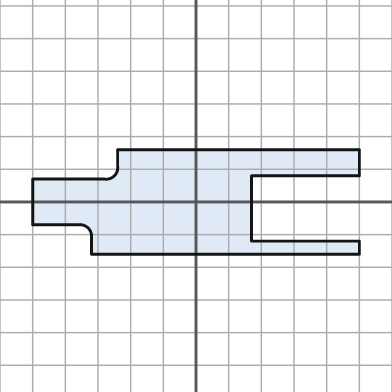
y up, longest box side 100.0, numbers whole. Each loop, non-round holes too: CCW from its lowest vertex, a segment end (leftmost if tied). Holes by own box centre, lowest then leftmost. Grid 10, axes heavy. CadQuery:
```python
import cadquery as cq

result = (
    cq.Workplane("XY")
    .moveTo(-32.0, -16.0)
    .lineTo(50.0, -16.0)
    .lineTo(50.0, -12.0)
    .lineTo(17.0, -12.0)
    .lineTo(17.0, 8.0)
    .lineTo(50.0, 8.0)
    .lineTo(50.0, 16.0)
    .lineTo(-24.0, 16.0)
    .lineTo(-24.0, 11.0)
    .threePointArc((-25.0, 8.0), (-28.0, 7.0))
    .lineTo(-50.0, 7.0)
    .lineTo(-50.0, -7.0)
    .lineTo(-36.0, -7.0)
    .threePointArc((-33.0, -8.0), (-32.0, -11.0))
    .close()
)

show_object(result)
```